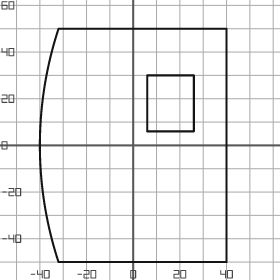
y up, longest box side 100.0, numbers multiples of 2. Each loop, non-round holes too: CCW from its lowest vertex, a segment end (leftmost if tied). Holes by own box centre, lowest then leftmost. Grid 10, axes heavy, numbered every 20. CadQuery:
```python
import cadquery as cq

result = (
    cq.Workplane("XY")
    .moveTo(-32.0, -50.0)
    .lineTo(40.0, -50.0)
    .lineTo(40.0, 50.0)
    .lineTo(-32.0, 50.0)
    .threePointArc((-40.0, 0.0), (-32.0, -50.0))
    .close()
    .moveTo(6.0, 6.0)
    .lineTo(26.0, 6.0)
    .lineTo(26.0, 30.0)
    .lineTo(6.0, 30.0)
    .close()
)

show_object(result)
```